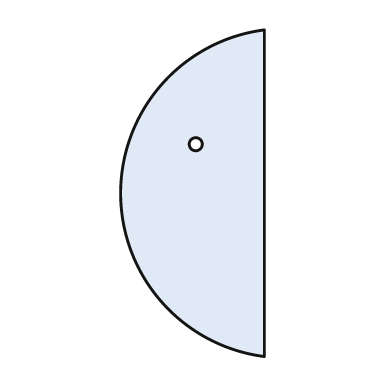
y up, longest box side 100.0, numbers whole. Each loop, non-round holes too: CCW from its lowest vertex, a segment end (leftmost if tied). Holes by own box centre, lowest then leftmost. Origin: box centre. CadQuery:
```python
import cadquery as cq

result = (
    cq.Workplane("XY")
    .moveTo(22.0, -50.0)
    .lineTo(22.0, 50.0)
    .threePointArc((-22.0, 0.0), (22.0, -50.0))
    .close()
    .moveTo(1.0, 15.0)
    .circle(2.0)
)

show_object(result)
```